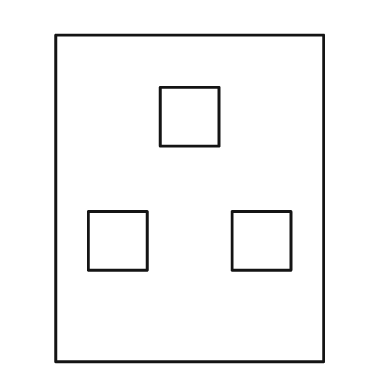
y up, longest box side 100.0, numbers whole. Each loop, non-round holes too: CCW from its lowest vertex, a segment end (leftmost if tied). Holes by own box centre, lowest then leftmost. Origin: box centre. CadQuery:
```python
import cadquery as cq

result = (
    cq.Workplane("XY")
    .moveTo(-41.0, -50.0)
    .lineTo(41.0, -50.0)
    .lineTo(41.0, 50.0)
    .lineTo(-41.0, 50.0)
    .close()
    .moveTo(-31.0, -22.0)
    .lineTo(-13.0, -22.0)
    .lineTo(-13.0, -4.0)
    .lineTo(-31.0, -4.0)
    .close()
    .moveTo(13.0, -22.0)
    .lineTo(31.0, -22.0)
    .lineTo(31.0, -4.0)
    .lineTo(13.0, -4.0)
    .close()
    .moveTo(-9.0, 16.0)
    .lineTo(9.0, 16.0)
    .lineTo(9.0, 34.0)
    .lineTo(-9.0, 34.0)
    .close()
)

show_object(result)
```